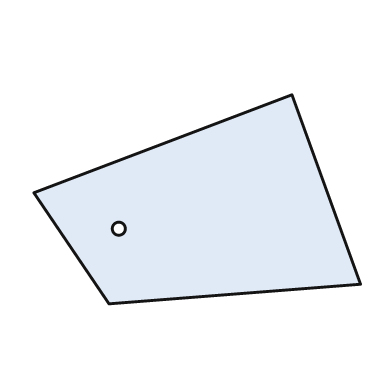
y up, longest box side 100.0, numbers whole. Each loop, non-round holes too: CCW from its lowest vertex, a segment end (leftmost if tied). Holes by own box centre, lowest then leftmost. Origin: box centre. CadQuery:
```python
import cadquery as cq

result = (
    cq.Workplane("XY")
    .moveTo(-27.0, -32.0)
    .lineTo(50.0, -26.0)
    .lineTo(29.0, 32.0)
    .lineTo(-50.0, 2.0)
    .close()
    .moveTo(-24.0, -9.0)
    .circle(2.0)
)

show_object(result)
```